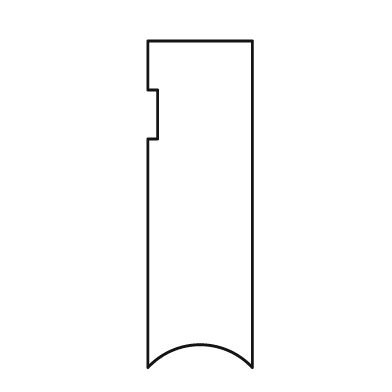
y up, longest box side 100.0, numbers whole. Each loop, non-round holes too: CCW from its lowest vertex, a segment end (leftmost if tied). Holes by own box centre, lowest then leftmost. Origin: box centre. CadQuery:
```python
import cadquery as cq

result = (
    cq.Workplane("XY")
    .moveTo(-16.0, -50.0)
    .threePointArc((0.0, -43.0), (16.0, -50.0))
    .lineTo(16.0, 50.0)
    .lineTo(-16.0, 50.0)
    .lineTo(-16.0, 35.0)
    .lineTo(-13.0, 35.0)
    .lineTo(-13.0, 20.0)
    .lineTo(-16.0, 20.0)
    .close()
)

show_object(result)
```